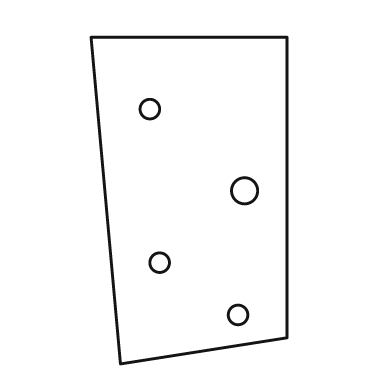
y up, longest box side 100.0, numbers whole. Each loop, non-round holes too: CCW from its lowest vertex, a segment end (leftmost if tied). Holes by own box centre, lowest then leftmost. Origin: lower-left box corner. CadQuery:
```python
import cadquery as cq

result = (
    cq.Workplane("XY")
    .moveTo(9.0, 0.0)
    .lineTo(60.0, 8.0)
    .lineTo(60.0, 100.0)
    .lineTo(0.0, 100.0)
    .close()
    .moveTo(45.0, 15.0)
    .circle(3.0)
    .moveTo(21.0, 31.0)
    .circle(3.0)
    .moveTo(47.0, 53.0)
    .circle(4.0)
    .moveTo(18.0, 78.0)
    .circle(3.0)
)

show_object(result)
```